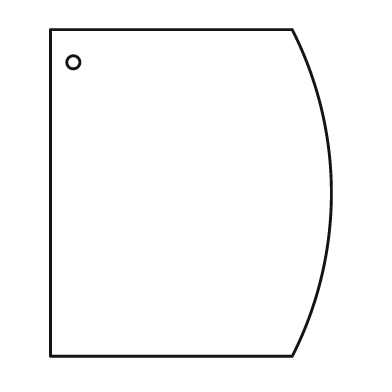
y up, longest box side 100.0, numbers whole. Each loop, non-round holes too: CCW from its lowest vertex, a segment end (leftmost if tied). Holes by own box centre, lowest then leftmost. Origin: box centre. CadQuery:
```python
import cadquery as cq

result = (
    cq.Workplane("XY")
    .moveTo(-43.0, -50.0)
    .lineTo(31.0, -50.0)
    .threePointArc((43.0, 0.0), (31.0, 50.0))
    .lineTo(-43.0, 50.0)
    .close()
    .moveTo(-36.0, 40.0)
    .circle(2.0)
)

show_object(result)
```